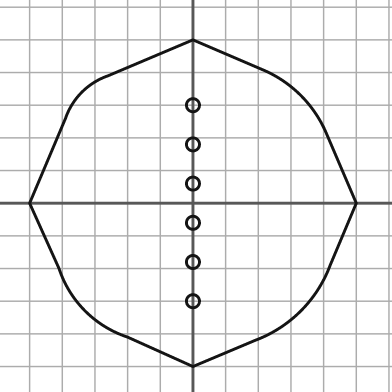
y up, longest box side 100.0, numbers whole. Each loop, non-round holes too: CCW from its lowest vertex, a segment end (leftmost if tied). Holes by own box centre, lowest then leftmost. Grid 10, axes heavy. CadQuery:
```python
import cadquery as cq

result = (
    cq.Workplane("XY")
    .moveTo(0.0, -50.0)
    .lineTo(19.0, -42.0)
    .threePointArc((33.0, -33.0), (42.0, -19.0))
    .lineTo(50.0, 0.0)
    .lineTo(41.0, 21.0)
    .threePointArc((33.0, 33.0), (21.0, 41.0))
    .lineTo(0.0, 50.0)
    .lineTo(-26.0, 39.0)
    .threePointArc((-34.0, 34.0), (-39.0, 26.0))
    .lineTo(-50.0, 0.0)
    .lineTo(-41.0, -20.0)
    .threePointArc((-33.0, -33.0), (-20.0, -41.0))
    .close()
    .moveTo(0.0, -30.0)
    .circle(2.0)
    .moveTo(0.0, -18.0)
    .circle(2.0)
    .moveTo(0.0, -6.0)
    .circle(2.0)
    .moveTo(0.0, 6.0)
    .circle(2.0)
    .moveTo(0.0, 18.0)
    .circle(2.0)
    .moveTo(0.0, 30.0)
    .circle(2.0)
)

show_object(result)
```